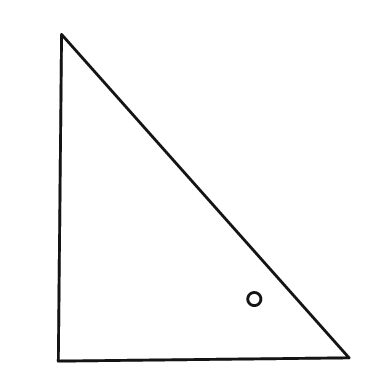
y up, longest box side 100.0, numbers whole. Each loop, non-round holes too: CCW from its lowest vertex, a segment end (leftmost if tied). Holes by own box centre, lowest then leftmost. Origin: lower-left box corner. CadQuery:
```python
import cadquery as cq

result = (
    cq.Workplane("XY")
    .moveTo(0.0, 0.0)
    .lineTo(89.0, 1.0)
    .lineTo(1.0, 100.0)
    .close()
    .moveTo(60.0, 19.0)
    .circle(2.0)
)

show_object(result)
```